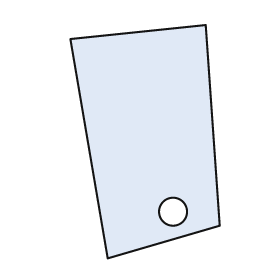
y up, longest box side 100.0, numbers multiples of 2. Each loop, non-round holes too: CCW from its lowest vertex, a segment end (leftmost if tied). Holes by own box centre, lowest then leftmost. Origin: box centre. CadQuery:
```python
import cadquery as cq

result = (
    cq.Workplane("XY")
    .moveTo(-16.0, -50.0)
    .lineTo(32.0, -36.0)
    .lineTo(26.0, 50.0)
    .lineTo(-32.0, 44.0)
    .close()
    .moveTo(12.0, -30.0)
    .circle(6.0)
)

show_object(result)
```